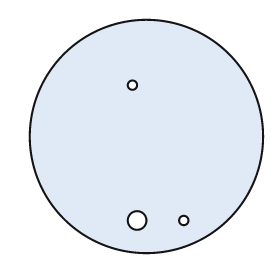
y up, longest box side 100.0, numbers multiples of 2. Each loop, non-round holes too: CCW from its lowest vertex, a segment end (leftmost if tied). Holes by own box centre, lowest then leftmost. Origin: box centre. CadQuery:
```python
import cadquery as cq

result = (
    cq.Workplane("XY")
    .moveTo(0.0, 0.0)
    .circle(50.0)
    .moveTo(-4.0, -36.0)
    .circle(4.0)
    .moveTo(16.0, -36.0)
    .circle(2.0)
    .moveTo(-6.0, 22.0)
    .circle(2.0)
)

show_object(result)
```